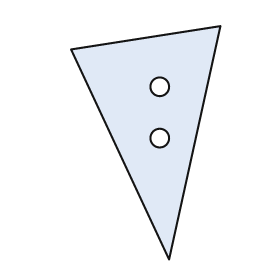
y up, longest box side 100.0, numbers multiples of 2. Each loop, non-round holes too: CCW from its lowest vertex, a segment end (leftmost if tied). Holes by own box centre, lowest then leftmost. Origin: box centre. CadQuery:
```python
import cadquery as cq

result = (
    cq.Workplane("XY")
    .moveTo(10.0, -50.0)
    .lineTo(32.0, 50.0)
    .lineTo(-32.0, 40.0)
    .close()
    .moveTo(6.0, 2.0)
    .circle(4.0)
    .moveTo(6.0, 24.0)
    .circle(4.0)
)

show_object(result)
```